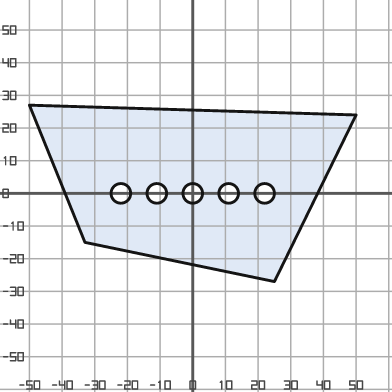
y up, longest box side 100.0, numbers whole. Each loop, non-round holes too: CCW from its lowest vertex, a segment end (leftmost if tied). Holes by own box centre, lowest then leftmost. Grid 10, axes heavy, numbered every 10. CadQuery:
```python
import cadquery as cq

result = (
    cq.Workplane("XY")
    .moveTo(25.0, -27.0)
    .lineTo(50.0, 24.0)
    .lineTo(-50.0, 27.0)
    .lineTo(-33.0, -15.0)
    .close()
    .moveTo(-22.0, 0.0)
    .circle(3.0)
    .moveTo(-11.0, 0.0)
    .circle(3.0)
    .moveTo(0.0, 0.0)
    .circle(3.0)
    .moveTo(11.0, 0.0)
    .circle(3.0)
    .moveTo(22.0, 0.0)
    .circle(3.0)
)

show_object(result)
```